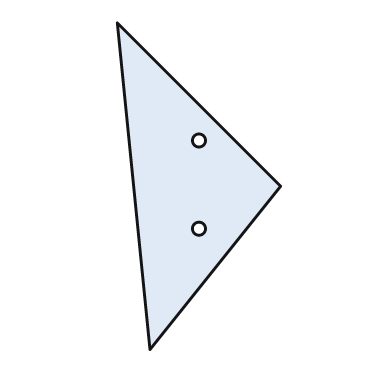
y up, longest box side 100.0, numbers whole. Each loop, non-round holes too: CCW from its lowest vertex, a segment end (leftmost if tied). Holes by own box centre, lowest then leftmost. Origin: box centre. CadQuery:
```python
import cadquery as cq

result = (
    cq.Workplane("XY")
    .moveTo(-15.0, -50.0)
    .lineTo(25.0, 0.0)
    .lineTo(-25.0, 50.0)
    .close()
    .moveTo(0.0, -13.0)
    .circle(2.0)
    .moveTo(0.0, 14.0)
    .circle(2.0)
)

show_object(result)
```